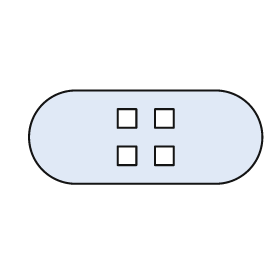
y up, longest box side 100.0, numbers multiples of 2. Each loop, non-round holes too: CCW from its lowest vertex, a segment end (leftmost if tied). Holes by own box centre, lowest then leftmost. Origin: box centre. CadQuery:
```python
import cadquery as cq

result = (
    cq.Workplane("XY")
    .moveTo(-30.0, -20.0)
    .lineTo(30.0, -20.0)
    .threePointArc((50.0, 0.0), (30.0, 20.0))
    .lineTo(-30.0, 20.0)
    .threePointArc((-50.0, 0.0), (-30.0, -20.0))
    .close()
    .moveTo(-12.0, -12.0)
    .lineTo(-4.0, -12.0)
    .lineTo(-4.0, -4.0)
    .lineTo(-12.0, -4.0)
    .close()
    .moveTo(4.0, -12.0)
    .lineTo(12.0, -12.0)
    .lineTo(12.0, -4.0)
    .lineTo(4.0, -4.0)
    .close()
    .moveTo(-12.0, 4.0)
    .lineTo(-4.0, 4.0)
    .lineTo(-4.0, 12.0)
    .lineTo(-12.0, 12.0)
    .close()
    .moveTo(4.0, 4.0)
    .lineTo(12.0, 4.0)
    .lineTo(12.0, 12.0)
    .lineTo(4.0, 12.0)
    .close()
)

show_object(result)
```